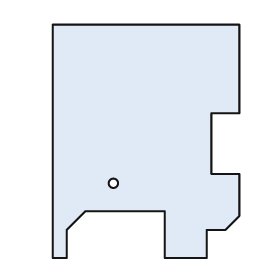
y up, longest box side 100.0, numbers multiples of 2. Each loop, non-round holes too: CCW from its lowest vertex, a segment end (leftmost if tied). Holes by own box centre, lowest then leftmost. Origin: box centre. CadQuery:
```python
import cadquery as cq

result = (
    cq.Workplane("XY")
    .moveTo(-40.0, -50.0)
    .lineTo(-34.0, -50.0)
    .lineTo(-34.0, -38.0)
    .lineTo(-26.0, -30.0)
    .lineTo(8.0, -30.0)
    .lineTo(8.0, -50.0)
    .lineTo(26.0, -50.0)
    .lineTo(26.0, -38.0)
    .lineTo(34.0, -38.0)
    .lineTo(40.0, -32.0)
    .lineTo(40.0, -14.0)
    .lineTo(28.0, -14.0)
    .lineTo(28.0, 12.0)
    .lineTo(40.0, 12.0)
    .lineTo(40.0, 50.0)
    .lineTo(-40.0, 50.0)
    .close()
    .moveTo(-14.0, -18.0)
    .circle(2.0)
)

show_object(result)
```